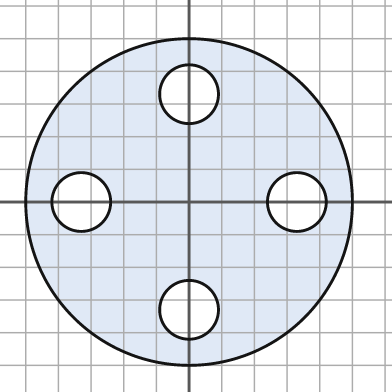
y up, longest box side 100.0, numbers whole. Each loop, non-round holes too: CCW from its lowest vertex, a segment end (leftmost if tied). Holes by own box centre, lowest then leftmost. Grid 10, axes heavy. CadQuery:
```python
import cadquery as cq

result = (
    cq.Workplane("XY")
    .moveTo(0.0, 0.0)
    .circle(50.0)
    .moveTo(0.0, -33.0)
    .circle(9.0)
    .moveTo(-33.0, 0.0)
    .circle(9.0)
    .moveTo(33.0, 0.0)
    .circle(9.0)
    .moveTo(0.0, 33.0)
    .circle(9.0)
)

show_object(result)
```